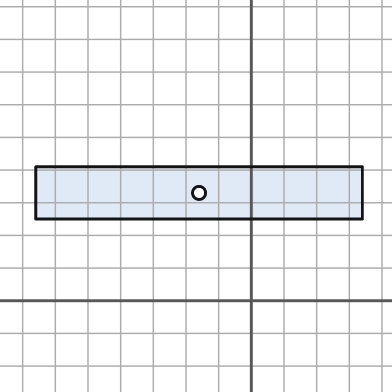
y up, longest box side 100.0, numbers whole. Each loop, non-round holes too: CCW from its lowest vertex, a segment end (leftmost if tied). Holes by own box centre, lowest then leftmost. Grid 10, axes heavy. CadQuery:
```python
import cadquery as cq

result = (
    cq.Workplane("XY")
    .moveTo(-66.0, 25.0)
    .lineTo(34.0, 25.0)
    .lineTo(34.0, 41.0)
    .lineTo(-66.0, 41.0)
    .close()
    .moveTo(-16.0, 33.0)
    .circle(2.0)
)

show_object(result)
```